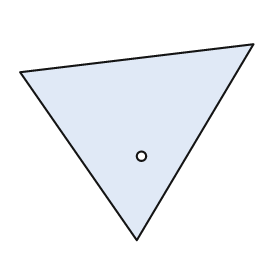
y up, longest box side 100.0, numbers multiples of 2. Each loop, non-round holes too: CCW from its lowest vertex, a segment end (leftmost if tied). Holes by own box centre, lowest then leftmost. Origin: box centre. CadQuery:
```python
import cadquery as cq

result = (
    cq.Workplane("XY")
    .moveTo(0.0, -42.0)
    .lineTo(50.0, 42.0)
    .lineTo(-50.0, 30.0)
    .close()
    .moveTo(2.0, -6.0)
    .circle(2.0)
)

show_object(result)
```